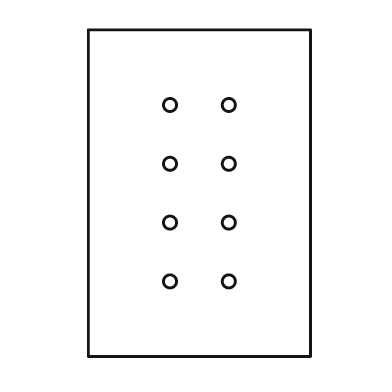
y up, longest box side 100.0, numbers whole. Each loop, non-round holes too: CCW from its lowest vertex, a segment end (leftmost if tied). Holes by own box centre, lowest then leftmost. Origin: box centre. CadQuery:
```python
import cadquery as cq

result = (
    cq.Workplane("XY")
    .moveTo(-34.0, -50.0)
    .lineTo(34.0, -50.0)
    .lineTo(34.0, 50.0)
    .lineTo(-34.0, 50.0)
    .close()
    .moveTo(-9.0, -27.0)
    .circle(2.0)
    .moveTo(9.0, -27.0)
    .circle(2.0)
    .moveTo(-9.0, -9.0)
    .circle(2.0)
    .moveTo(9.0, -9.0)
    .circle(2.0)
    .moveTo(-9.0, 9.0)
    .circle(2.0)
    .moveTo(9.0, 9.0)
    .circle(2.0)
    .moveTo(-9.0, 27.0)
    .circle(2.0)
    .moveTo(9.0, 27.0)
    .circle(2.0)
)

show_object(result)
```